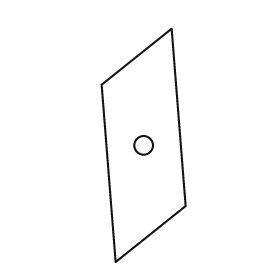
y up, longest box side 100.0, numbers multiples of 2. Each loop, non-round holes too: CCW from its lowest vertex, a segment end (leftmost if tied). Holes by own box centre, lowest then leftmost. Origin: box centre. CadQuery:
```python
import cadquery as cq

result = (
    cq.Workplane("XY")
    .moveTo(-12.0, -50.0)
    .lineTo(18.0, -26.0)
    .lineTo(12.0, 50.0)
    .lineTo(-18.0, 26.0)
    .close()
    .moveTo(0.0, 0.0)
    .circle(4.0)
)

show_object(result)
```